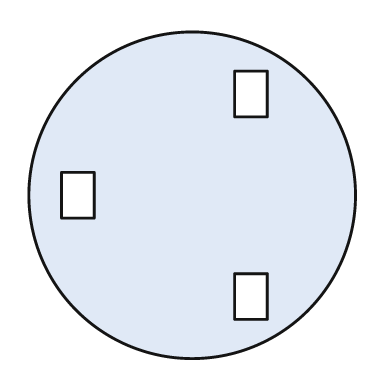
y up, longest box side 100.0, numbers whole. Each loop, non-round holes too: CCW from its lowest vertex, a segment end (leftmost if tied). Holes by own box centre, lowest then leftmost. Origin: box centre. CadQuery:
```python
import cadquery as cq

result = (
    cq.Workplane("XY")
    .moveTo(0.0, 0.0)
    .circle(50.0)
    .moveTo(13.0, -38.0)
    .lineTo(23.0, -38.0)
    .lineTo(23.0, -24.0)
    .lineTo(13.0, -24.0)
    .close()
    .moveTo(-40.0, -7.0)
    .lineTo(-30.0, -7.0)
    .lineTo(-30.0, 7.0)
    .lineTo(-40.0, 7.0)
    .close()
    .moveTo(13.0, 24.0)
    .lineTo(23.0, 24.0)
    .lineTo(23.0, 38.0)
    .lineTo(13.0, 38.0)
    .close()
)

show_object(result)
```